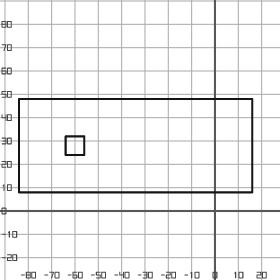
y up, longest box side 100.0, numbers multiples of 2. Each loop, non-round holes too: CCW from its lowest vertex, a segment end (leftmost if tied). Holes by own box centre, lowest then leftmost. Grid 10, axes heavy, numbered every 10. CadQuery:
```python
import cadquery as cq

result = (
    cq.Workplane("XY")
    .moveTo(-84.0, 8.0)
    .lineTo(16.0, 8.0)
    .lineTo(16.0, 48.0)
    .lineTo(-84.0, 48.0)
    .close()
    .moveTo(-64.0, 24.0)
    .lineTo(-56.0, 24.0)
    .lineTo(-56.0, 32.0)
    .lineTo(-64.0, 32.0)
    .close()
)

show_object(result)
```